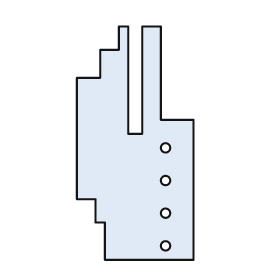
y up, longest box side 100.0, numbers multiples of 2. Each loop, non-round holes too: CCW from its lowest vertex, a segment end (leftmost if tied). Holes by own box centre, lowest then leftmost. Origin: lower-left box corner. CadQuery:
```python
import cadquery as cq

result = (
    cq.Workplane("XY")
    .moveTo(12.0, 0.0)
    .lineTo(50.0, 0.0)
    .lineTo(50.0, 60.0)
    .lineTo(36.0, 60.0)
    .lineTo(36.0, 100.0)
    .lineTo(28.0, 100.0)
    .lineTo(28.0, 54.0)
    .lineTo(22.0, 54.0)
    .lineTo(22.0, 100.0)
    .lineTo(18.0, 100.0)
    .lineTo(18.0, 90.0)
    .lineTo(10.0, 90.0)
    .lineTo(10.0, 78.0)
    .lineTo(0.0, 78.0)
    .lineTo(0.0, 26.0)
    .lineTo(8.0, 26.0)
    .lineTo(8.0, 16.0)
    .lineTo(12.0, 16.0)
    .close()
    .moveTo(38.0, 6.0)
    .circle(2.0)
    .moveTo(38.0, 20.0)
    .circle(2.0)
    .moveTo(38.0, 34.0)
    .circle(2.0)
    .moveTo(38.0, 48.0)
    .circle(2.0)
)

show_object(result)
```